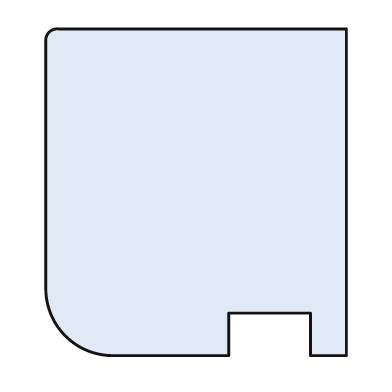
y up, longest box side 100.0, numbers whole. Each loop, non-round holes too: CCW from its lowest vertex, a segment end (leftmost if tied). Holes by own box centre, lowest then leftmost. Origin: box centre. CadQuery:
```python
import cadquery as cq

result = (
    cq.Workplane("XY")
    .moveTo(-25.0, -50.0)
    .lineTo(10.0, -50.0)
    .lineTo(10.0, -37.0)
    .lineTo(35.0, -37.0)
    .lineTo(35.0, -50.0)
    .lineTo(46.0, -50.0)
    .lineTo(46.0, 50.0)
    .lineTo(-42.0, 50.0)
    .threePointArc((-45.0, 49.0), (-46.0, 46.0))
    .lineTo(-46.0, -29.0)
    .threePointArc((-40.0, -44.0), (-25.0, -50.0))
    .close()
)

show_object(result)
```